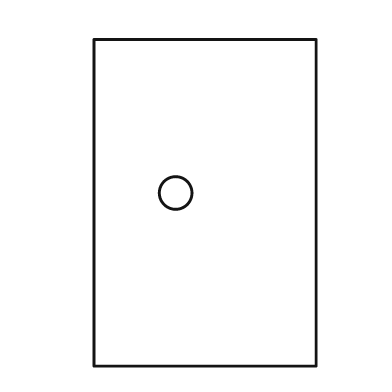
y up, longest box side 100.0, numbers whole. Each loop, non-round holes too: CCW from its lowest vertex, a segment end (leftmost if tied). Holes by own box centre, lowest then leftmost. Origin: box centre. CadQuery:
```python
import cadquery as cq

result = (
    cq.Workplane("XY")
    .moveTo(-34.0, -50.0)
    .lineTo(34.0, -50.0)
    .lineTo(34.0, 50.0)
    .lineTo(-34.0, 50.0)
    .close()
    .moveTo(-9.0, 3.0)
    .circle(5.0)
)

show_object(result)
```